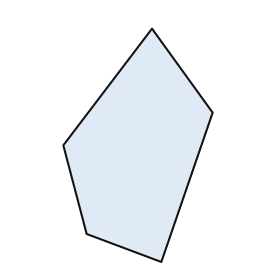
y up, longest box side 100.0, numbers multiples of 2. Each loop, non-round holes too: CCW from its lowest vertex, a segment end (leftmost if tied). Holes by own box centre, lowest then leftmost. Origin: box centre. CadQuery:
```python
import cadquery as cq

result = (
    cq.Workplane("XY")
    .moveTo(10.0, -50.0)
    .lineTo(32.0, 14.0)
    .lineTo(6.0, 50.0)
    .lineTo(-32.0, 0.0)
    .lineTo(-22.0, -38.0)
    .close()
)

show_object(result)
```